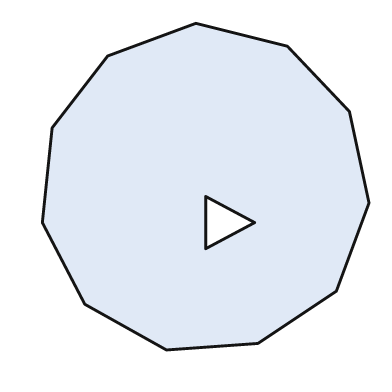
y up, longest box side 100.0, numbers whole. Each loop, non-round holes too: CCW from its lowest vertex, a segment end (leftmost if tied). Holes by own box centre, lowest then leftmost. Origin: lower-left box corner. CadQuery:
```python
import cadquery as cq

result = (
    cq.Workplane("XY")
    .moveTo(38.0, 0.0)
    .lineTo(66.0, 2.0)
    .lineTo(90.0, 18.0)
    .lineTo(100.0, 45.0)
    .lineTo(94.0, 73.0)
    .lineTo(75.0, 93.0)
    .lineTo(47.0, 100.0)
    .lineTo(20.0, 90.0)
    .lineTo(3.0, 68.0)
    .lineTo(0.0, 39.0)
    .lineTo(13.0, 14.0)
    .close()
    .moveTo(50.0, 31.0)
    .lineTo(65.0, 39.0)
    .lineTo(50.0, 47.0)
    .close()
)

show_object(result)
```